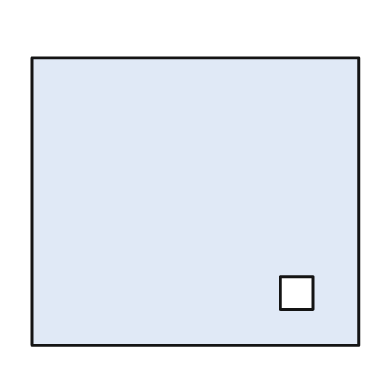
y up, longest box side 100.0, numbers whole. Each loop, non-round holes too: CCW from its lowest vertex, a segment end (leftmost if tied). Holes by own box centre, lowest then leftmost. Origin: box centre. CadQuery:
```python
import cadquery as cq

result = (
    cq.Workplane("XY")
    .moveTo(-50.0, -44.0)
    .lineTo(50.0, -44.0)
    .lineTo(50.0, 44.0)
    .lineTo(-50.0, 44.0)
    .close()
    .moveTo(26.0, -33.0)
    .lineTo(36.0, -33.0)
    .lineTo(36.0, -23.0)
    .lineTo(26.0, -23.0)
    .close()
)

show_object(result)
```